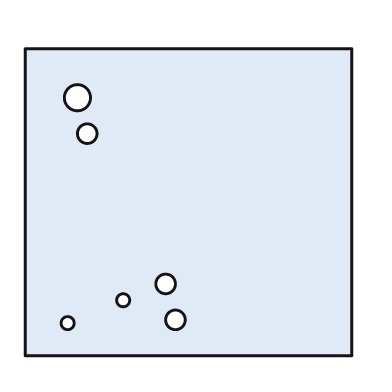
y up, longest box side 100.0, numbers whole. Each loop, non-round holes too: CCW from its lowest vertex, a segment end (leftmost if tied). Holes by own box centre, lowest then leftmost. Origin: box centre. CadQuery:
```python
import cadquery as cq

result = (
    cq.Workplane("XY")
    .moveTo(-50.0, -47.0)
    .lineTo(50.0, -47.0)
    .lineTo(50.0, 47.0)
    .lineTo(-50.0, 47.0)
    .close()
    .moveTo(-37.0, -37.0)
    .circle(2.0)
    .moveTo(-4.0, -36.0)
    .circle(3.0)
    .moveTo(-20.0, -30.0)
    .circle(2.0)
    .moveTo(-7.0, -25.0)
    .circle(3.0)
    .moveTo(-31.0, 21.0)
    .circle(3.0)
    .moveTo(-34.0, 32.0)
    .circle(4.0)
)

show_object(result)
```